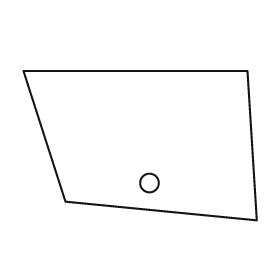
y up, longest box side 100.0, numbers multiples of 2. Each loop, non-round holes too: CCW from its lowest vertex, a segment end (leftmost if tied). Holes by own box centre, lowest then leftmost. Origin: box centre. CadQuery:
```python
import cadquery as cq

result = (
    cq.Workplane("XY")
    .moveTo(50.0, -32.0)
    .lineTo(46.0, 32.0)
    .lineTo(-50.0, 32.0)
    .lineTo(-32.0, -24.0)
    .close()
    .moveTo(4.0, -16.0)
    .circle(4.0)
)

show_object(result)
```